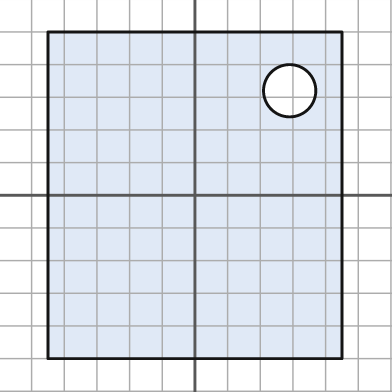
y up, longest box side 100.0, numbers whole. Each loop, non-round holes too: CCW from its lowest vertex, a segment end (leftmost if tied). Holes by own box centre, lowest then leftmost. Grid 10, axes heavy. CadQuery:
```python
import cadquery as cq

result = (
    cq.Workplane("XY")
    .moveTo(-45.0, -50.0)
    .lineTo(45.0, -50.0)
    .lineTo(45.0, 50.0)
    .lineTo(-45.0, 50.0)
    .close()
    .moveTo(29.0, 32.0)
    .circle(8.0)
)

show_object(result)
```